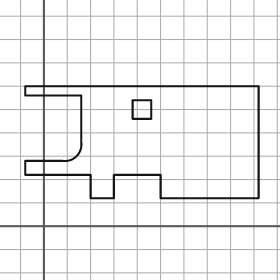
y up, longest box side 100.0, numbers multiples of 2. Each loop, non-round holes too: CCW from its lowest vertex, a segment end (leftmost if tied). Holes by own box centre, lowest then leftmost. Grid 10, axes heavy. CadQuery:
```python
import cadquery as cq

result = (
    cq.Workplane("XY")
    .moveTo(20.0, 12.0)
    .lineTo(30.0, 12.0)
    .lineTo(30.0, 22.0)
    .lineTo(50.0, 22.0)
    .lineTo(50.0, 12.0)
    .lineTo(92.0, 12.0)
    .lineTo(92.0, 60.0)
    .lineTo(-8.0, 60.0)
    .lineTo(-8.0, 56.0)
    .lineTo(16.0, 56.0)
    .lineTo(16.0, 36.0)
    .threePointArc((14.0, 30.0), (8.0, 28.0))
    .lineTo(-8.0, 28.0)
    .lineTo(-8.0, 22.0)
    .lineTo(20.0, 22.0)
    .close()
    .moveTo(38.0, 46.0)
    .lineTo(46.0, 46.0)
    .lineTo(46.0, 54.0)
    .lineTo(38.0, 54.0)
    .close()
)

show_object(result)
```